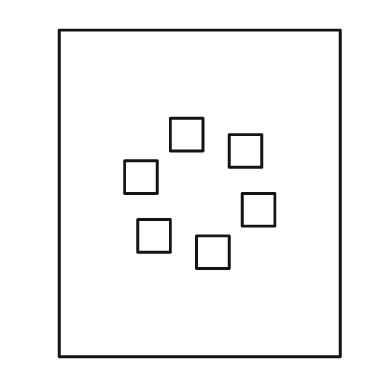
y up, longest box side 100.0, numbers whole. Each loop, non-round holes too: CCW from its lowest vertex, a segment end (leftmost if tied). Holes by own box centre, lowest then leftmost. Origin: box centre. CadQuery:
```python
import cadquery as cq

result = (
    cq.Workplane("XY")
    .moveTo(-43.0, -50.0)
    .lineTo(43.0, -50.0)
    .lineTo(43.0, 50.0)
    .lineTo(-43.0, 50.0)
    .close()
    .moveTo(-1.0, -23.0)
    .lineTo(9.0, -23.0)
    .lineTo(9.0, -13.0)
    .lineTo(-1.0, -13.0)
    .close()
    .moveTo(-19.0, -18.0)
    .lineTo(-9.0, -18.0)
    .lineTo(-9.0, -8.0)
    .lineTo(-19.0, -8.0)
    .close()
    .moveTo(13.0, -10.0)
    .lineTo(23.0, -10.0)
    .lineTo(23.0, 0.0)
    .lineTo(13.0, 0.0)
    .close()
    .moveTo(-23.0, 0.0)
    .lineTo(-13.0, 0.0)
    .lineTo(-13.0, 10.0)
    .lineTo(-23.0, 10.0)
    .close()
    .moveTo(9.0, 8.0)
    .lineTo(19.0, 8.0)
    .lineTo(19.0, 18.0)
    .lineTo(9.0, 18.0)
    .close()
    .moveTo(-9.0, 13.0)
    .lineTo(1.0, 13.0)
    .lineTo(1.0, 23.0)
    .lineTo(-9.0, 23.0)
    .close()
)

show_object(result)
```